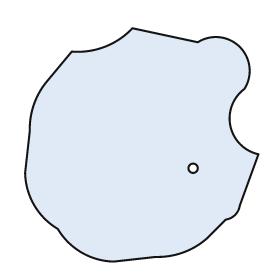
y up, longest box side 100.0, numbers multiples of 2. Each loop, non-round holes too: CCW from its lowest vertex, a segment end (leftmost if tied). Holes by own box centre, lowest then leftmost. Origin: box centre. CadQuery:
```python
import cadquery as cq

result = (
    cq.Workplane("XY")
    .moveTo(-12.0, -50.0)
    .lineTo(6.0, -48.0)
    .threePointArc((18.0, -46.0), (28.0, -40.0))
    .lineTo(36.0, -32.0)
    .threePointArc((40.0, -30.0), (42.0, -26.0))
    .lineTo(50.0, -4.0)
    .threePointArc((38.0, 8.0), (44.0, 24.0))
    .threePointArc((42.0, 42.0), (24.0, 44.0))
    .lineTo(-4.0, 50.0)
    .threePointArc((-16.0, 42.0), (-30.0, 40.0))
    .lineTo(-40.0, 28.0)
    .threePointArc((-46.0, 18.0), (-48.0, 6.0))
    .lineTo(-50.0, -12.0)
    .threePointArc((-46.0, -26.0), (-36.0, -36.0))
    .threePointArc((-26.0, -46.0), (-12.0, -50.0))
    .close()
    .moveTo(22.0, -10.0)
    .circle(2.0)
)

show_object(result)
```